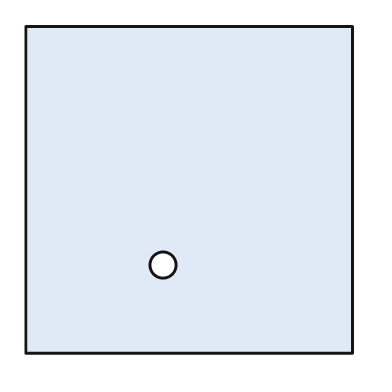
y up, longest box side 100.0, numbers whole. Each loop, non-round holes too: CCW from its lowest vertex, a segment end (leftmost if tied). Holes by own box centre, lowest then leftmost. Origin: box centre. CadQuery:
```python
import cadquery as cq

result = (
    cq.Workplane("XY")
    .moveTo(-50.0, -50.0)
    .lineTo(50.0, -50.0)
    .lineTo(50.0, 50.0)
    .lineTo(-50.0, 50.0)
    .close()
    .moveTo(-8.0, -23.0)
    .circle(4.0)
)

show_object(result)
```